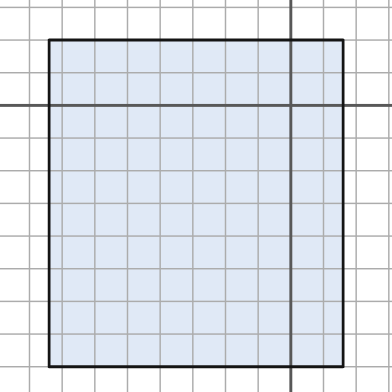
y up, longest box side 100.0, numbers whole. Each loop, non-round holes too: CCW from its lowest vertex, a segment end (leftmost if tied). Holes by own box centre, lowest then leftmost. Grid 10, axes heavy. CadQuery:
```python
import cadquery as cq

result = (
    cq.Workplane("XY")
    .moveTo(-74.0, -80.0)
    .lineTo(16.0, -80.0)
    .lineTo(16.0, 20.0)
    .lineTo(-74.0, 20.0)
    .close()
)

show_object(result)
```